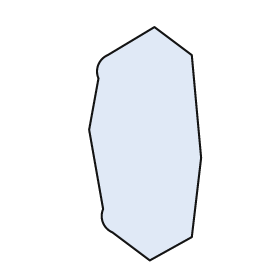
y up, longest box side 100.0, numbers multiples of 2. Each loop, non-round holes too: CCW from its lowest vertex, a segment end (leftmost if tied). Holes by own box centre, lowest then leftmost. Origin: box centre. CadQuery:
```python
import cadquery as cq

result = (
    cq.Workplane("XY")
    .moveTo(2.0, -50.0)
    .lineTo(20.0, -40.0)
    .lineTo(24.0, -6.0)
    .lineTo(20.0, 38.0)
    .lineTo(4.0, 50.0)
    .lineTo(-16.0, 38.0)
    .threePointArc((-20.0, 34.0), (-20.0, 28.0))
    .lineTo(-24.0, 6.0)
    .lineTo(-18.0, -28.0)
    .threePointArc((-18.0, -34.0), (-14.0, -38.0))
    .close()
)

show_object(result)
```